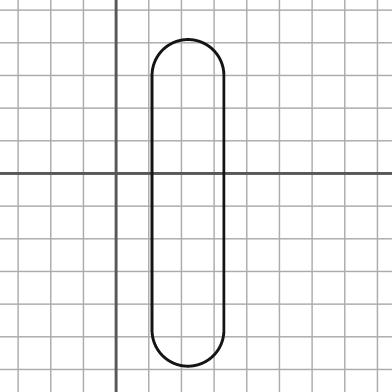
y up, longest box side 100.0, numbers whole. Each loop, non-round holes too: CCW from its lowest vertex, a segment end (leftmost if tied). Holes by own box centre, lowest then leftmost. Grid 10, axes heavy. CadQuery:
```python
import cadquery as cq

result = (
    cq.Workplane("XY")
    .moveTo(11.0, -48.0)
    .threePointArc((22.0, -59.0), (33.0, -48.0))
    .lineTo(33.0, 30.0)
    .threePointArc((22.0, 41.0), (11.0, 30.0))
    .close()
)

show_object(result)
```